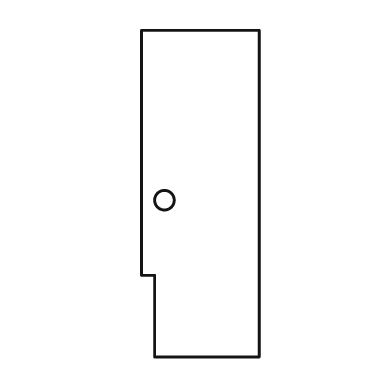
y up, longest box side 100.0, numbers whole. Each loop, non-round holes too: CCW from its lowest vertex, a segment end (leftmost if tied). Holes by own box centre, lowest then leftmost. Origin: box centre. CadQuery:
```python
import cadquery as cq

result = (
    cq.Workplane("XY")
    .moveTo(-14.0, -50.0)
    .lineTo(18.0, -50.0)
    .lineTo(18.0, 50.0)
    .lineTo(-18.0, 50.0)
    .lineTo(-18.0, -25.0)
    .lineTo(-14.0, -25.0)
    .close()
    .moveTo(-11.0, -2.0)
    .circle(3.0)
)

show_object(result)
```